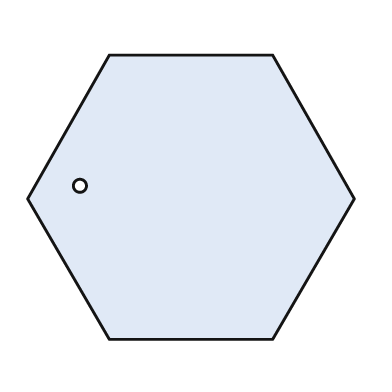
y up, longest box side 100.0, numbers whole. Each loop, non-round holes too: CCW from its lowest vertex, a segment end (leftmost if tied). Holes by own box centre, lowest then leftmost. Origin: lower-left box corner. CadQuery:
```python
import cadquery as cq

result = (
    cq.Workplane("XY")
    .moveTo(25.0, 0.0)
    .lineTo(75.0, 0.0)
    .lineTo(100.0, 43.0)
    .lineTo(75.0, 87.0)
    .lineTo(25.0, 87.0)
    .lineTo(0.0, 43.0)
    .close()
    .moveTo(16.0, 47.0)
    .circle(2.0)
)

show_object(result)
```